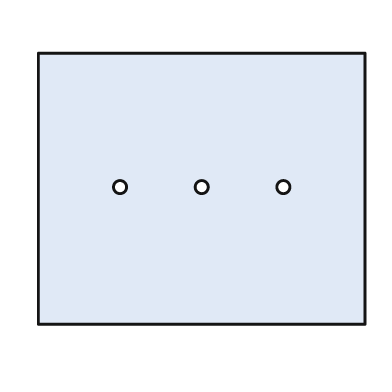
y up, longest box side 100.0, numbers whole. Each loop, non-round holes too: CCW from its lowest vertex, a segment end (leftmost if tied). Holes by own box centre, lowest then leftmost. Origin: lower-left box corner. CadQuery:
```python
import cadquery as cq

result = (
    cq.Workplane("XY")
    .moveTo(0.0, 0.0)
    .lineTo(100.0, 0.0)
    .lineTo(100.0, 83.0)
    .lineTo(0.0, 83.0)
    .close()
    .moveTo(25.0, 42.0)
    .circle(2.0)
    .moveTo(50.0, 42.0)
    .circle(2.0)
    .moveTo(75.0, 42.0)
    .circle(2.0)
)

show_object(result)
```